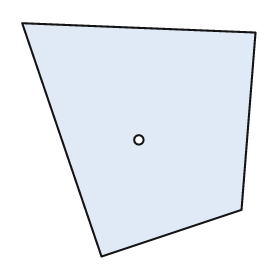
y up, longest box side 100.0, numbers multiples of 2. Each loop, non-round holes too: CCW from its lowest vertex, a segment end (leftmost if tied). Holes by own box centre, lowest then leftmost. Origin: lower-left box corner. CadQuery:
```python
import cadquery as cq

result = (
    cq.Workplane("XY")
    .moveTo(34.0, 0.0)
    .lineTo(94.0, 20.0)
    .lineTo(100.0, 96.0)
    .lineTo(0.0, 100.0)
    .close()
    .moveTo(50.0, 50.0)
    .circle(2.0)
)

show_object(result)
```